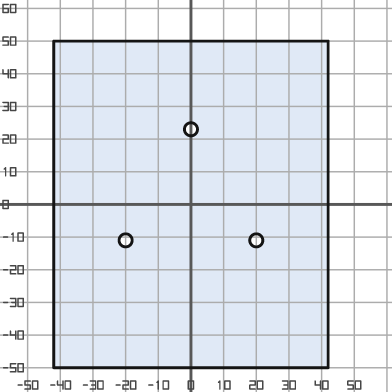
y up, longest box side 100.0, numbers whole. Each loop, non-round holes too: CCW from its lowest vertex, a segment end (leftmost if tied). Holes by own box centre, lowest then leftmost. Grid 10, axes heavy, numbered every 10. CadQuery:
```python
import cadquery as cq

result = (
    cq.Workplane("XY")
    .moveTo(-42.0, -50.0)
    .lineTo(42.0, -50.0)
    .lineTo(42.0, 50.0)
    .lineTo(-42.0, 50.0)
    .close()
    .moveTo(-20.0, -11.0)
    .circle(2.0)
    .moveTo(20.0, -11.0)
    .circle(2.0)
    .moveTo(0.0, 23.0)
    .circle(2.0)
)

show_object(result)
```